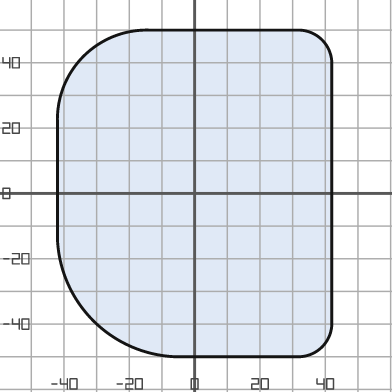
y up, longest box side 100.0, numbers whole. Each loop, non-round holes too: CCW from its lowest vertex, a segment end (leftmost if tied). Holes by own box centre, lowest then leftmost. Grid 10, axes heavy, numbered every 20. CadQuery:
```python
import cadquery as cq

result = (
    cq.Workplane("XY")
    .moveTo(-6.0, -50.0)
    .lineTo(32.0, -50.0)
    .threePointArc((39.0, -47.0), (42.0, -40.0))
    .lineTo(42.0, 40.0)
    .threePointArc((39.0, 47.0), (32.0, 50.0))
    .lineTo(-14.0, 50.0)
    .threePointArc((-34.0, 42.0), (-42.0, 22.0))
    .lineTo(-42.0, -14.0)
    .threePointArc((-31.0, -39.0), (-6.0, -50.0))
    .close()
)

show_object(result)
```